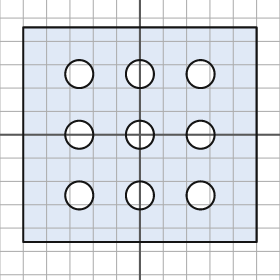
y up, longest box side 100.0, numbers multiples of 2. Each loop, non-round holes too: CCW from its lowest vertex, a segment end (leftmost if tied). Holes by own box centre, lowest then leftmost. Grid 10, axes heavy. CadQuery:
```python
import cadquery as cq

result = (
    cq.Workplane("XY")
    .moveTo(-50.0, -46.0)
    .lineTo(50.0, -46.0)
    .lineTo(50.0, 46.0)
    .lineTo(-50.0, 46.0)
    .close()
    .moveTo(-26.0, -26.0)
    .circle(6.0)
    .moveTo(0.0, -26.0)
    .circle(6.0)
    .moveTo(26.0, -26.0)
    .circle(6.0)
    .moveTo(-26.0, 0.0)
    .circle(6.0)
    .moveTo(0.0, 0.0)
    .circle(6.0)
    .moveTo(26.0, 0.0)
    .circle(6.0)
    .moveTo(-26.0, 26.0)
    .circle(6.0)
    .moveTo(0.0, 26.0)
    .circle(6.0)
    .moveTo(26.0, 26.0)
    .circle(6.0)
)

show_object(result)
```